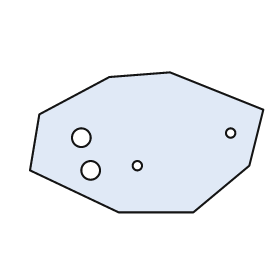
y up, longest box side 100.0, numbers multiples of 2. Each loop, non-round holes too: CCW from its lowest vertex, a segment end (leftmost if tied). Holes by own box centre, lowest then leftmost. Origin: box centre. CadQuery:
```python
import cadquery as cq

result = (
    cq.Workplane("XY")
    .moveTo(-12.0, -30.0)
    .lineTo(20.0, -30.0)
    .lineTo(44.0, -10.0)
    .lineTo(50.0, 14.0)
    .lineTo(10.0, 30.0)
    .lineTo(-16.0, 28.0)
    .lineTo(-46.0, 12.0)
    .lineTo(-50.0, -12.0)
    .close()
    .moveTo(-24.0, -12.0)
    .circle(4.0)
    .moveTo(-4.0, -10.0)
    .circle(2.0)
    .moveTo(-28.0, 2.0)
    .circle(4.0)
    .moveTo(36.0, 4.0)
    .circle(2.0)
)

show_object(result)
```